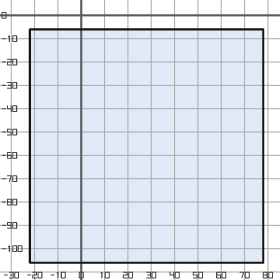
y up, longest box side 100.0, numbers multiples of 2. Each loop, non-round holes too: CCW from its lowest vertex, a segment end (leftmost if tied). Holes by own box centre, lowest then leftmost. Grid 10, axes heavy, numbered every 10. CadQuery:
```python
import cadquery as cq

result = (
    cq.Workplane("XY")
    .moveTo(-22.0, -106.0)
    .lineTo(78.0, -106.0)
    .lineTo(78.0, -6.0)
    .lineTo(-22.0, -6.0)
    .close()
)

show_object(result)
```